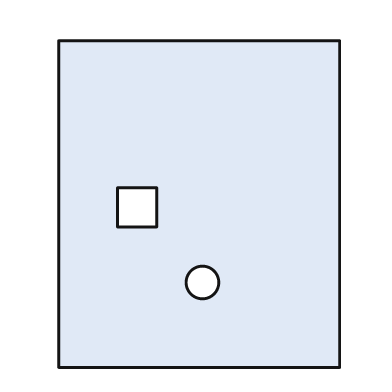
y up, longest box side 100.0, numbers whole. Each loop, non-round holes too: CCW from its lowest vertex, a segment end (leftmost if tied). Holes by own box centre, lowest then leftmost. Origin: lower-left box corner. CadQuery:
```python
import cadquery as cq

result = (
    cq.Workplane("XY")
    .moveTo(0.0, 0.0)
    .lineTo(86.0, 0.0)
    .lineTo(86.0, 100.0)
    .lineTo(0.0, 100.0)
    .close()
    .moveTo(44.0, 26.0)
    .circle(5.0)
    .moveTo(18.0, 43.0)
    .lineTo(30.0, 43.0)
    .lineTo(30.0, 55.0)
    .lineTo(18.0, 55.0)
    .close()
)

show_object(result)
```